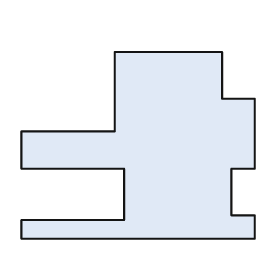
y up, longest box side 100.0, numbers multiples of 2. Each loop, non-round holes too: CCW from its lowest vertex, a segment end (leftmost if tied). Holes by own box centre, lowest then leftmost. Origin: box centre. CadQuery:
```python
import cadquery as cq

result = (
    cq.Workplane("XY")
    .moveTo(-50.0, -40.0)
    .lineTo(50.0, -40.0)
    .lineTo(50.0, -30.0)
    .lineTo(40.0, -30.0)
    .lineTo(40.0, -10.0)
    .lineTo(50.0, -10.0)
    .lineTo(50.0, 20.0)
    .lineTo(36.0, 20.0)
    .lineTo(36.0, 40.0)
    .lineTo(-10.0, 40.0)
    .lineTo(-10.0, 6.0)
    .lineTo(-50.0, 6.0)
    .lineTo(-50.0, -10.0)
    .lineTo(-6.0, -10.0)
    .lineTo(-6.0, -32.0)
    .lineTo(-50.0, -32.0)
    .close()
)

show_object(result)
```